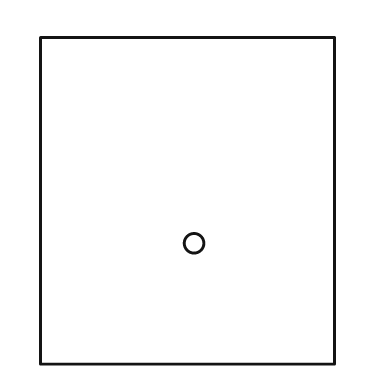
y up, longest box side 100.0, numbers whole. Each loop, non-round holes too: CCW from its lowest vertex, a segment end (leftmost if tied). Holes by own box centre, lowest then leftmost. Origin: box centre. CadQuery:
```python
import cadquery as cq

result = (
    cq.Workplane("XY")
    .moveTo(-45.0, -50.0)
    .lineTo(45.0, -50.0)
    .lineTo(45.0, 50.0)
    .lineTo(-45.0, 50.0)
    .close()
    .moveTo(2.0, -13.0)
    .circle(3.0)
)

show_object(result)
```